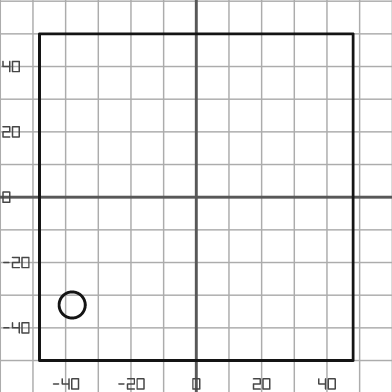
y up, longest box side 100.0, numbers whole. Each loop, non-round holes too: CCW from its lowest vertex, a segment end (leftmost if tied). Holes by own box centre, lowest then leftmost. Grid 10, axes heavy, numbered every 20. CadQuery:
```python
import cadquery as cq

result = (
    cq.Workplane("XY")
    .moveTo(-48.0, -50.0)
    .lineTo(48.0, -50.0)
    .lineTo(48.0, 50.0)
    .lineTo(-48.0, 50.0)
    .close()
    .moveTo(-38.0, -33.0)
    .circle(4.0)
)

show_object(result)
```